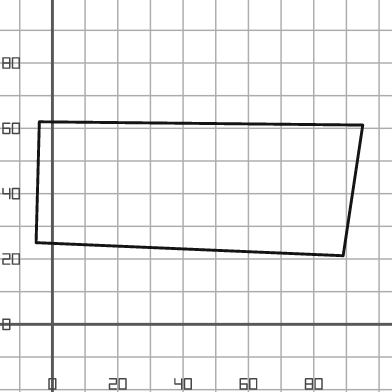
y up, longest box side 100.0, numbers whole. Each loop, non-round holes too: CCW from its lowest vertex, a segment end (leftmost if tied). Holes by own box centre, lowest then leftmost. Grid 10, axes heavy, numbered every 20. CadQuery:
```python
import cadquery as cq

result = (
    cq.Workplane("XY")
    .moveTo(89.0, 21.0)
    .lineTo(95.0, 61.0)
    .lineTo(-4.0, 62.0)
    .lineTo(-5.0, 25.0)
    .close()
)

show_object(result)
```